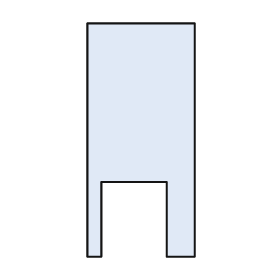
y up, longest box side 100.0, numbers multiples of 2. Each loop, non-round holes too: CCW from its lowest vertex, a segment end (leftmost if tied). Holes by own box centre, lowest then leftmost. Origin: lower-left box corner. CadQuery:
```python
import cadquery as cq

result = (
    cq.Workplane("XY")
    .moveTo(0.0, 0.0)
    .lineTo(6.0, 0.0)
    .lineTo(6.0, 32.0)
    .lineTo(34.0, 32.0)
    .lineTo(34.0, 0.0)
    .lineTo(46.0, 0.0)
    .lineTo(46.0, 100.0)
    .lineTo(0.0, 100.0)
    .close()
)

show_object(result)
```